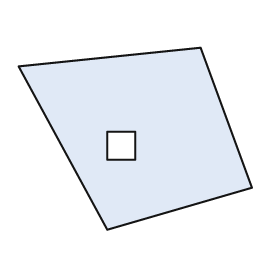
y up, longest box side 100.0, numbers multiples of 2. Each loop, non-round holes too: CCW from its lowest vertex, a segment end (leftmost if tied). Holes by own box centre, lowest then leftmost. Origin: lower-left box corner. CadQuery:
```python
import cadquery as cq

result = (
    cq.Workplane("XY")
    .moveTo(38.0, 0.0)
    .lineTo(100.0, 18.0)
    .lineTo(78.0, 78.0)
    .lineTo(0.0, 70.0)
    .close()
    .moveTo(38.0, 30.0)
    .lineTo(50.0, 30.0)
    .lineTo(50.0, 42.0)
    .lineTo(38.0, 42.0)
    .close()
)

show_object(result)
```